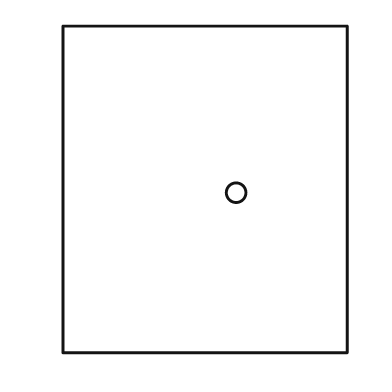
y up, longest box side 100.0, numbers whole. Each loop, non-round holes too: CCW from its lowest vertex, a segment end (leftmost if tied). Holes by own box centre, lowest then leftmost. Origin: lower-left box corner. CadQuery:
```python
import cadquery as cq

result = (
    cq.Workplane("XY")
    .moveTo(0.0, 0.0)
    .lineTo(87.0, 0.0)
    .lineTo(87.0, 100.0)
    .lineTo(0.0, 100.0)
    .close()
    .moveTo(53.0, 49.0)
    .circle(3.0)
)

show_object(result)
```